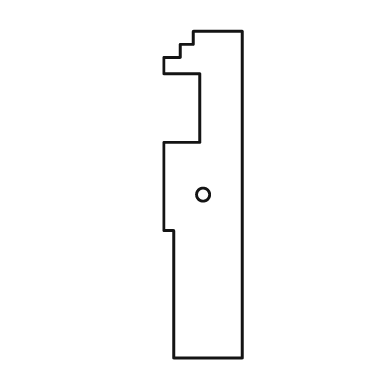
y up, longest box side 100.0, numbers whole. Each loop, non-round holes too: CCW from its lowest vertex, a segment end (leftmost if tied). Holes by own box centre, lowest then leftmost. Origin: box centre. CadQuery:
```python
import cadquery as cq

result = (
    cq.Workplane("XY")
    .moveTo(-9.0, -50.0)
    .lineTo(12.0, -50.0)
    .lineTo(12.0, 50.0)
    .lineTo(-3.0, 50.0)
    .lineTo(-3.0, 46.0)
    .lineTo(-7.0, 46.0)
    .lineTo(-7.0, 42.0)
    .lineTo(-12.0, 42.0)
    .lineTo(-12.0, 37.0)
    .lineTo(-1.0, 37.0)
    .lineTo(-1.0, 16.0)
    .lineTo(-12.0, 16.0)
    .lineTo(-12.0, -11.0)
    .lineTo(-9.0, -11.0)
    .close()
    .moveTo(0.0, 0.0)
    .circle(2.0)
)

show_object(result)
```